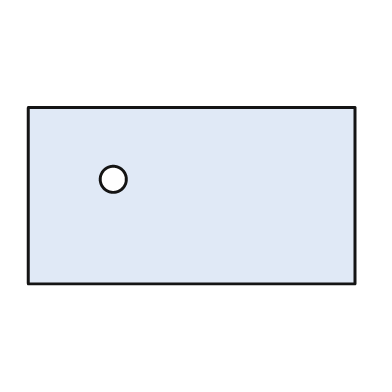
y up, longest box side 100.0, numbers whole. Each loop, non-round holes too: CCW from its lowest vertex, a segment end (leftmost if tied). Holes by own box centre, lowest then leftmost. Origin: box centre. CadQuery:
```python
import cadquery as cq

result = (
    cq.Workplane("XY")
    .moveTo(-50.0, -27.0)
    .lineTo(50.0, -27.0)
    .lineTo(50.0, 27.0)
    .lineTo(-50.0, 27.0)
    .close()
    .moveTo(-24.0, 5.0)
    .circle(4.0)
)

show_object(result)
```